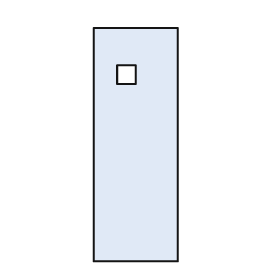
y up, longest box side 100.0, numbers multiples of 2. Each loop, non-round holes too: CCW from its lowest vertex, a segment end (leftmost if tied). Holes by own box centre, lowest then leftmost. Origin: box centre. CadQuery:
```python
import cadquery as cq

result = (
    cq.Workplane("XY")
    .moveTo(-18.0, -50.0)
    .lineTo(18.0, -50.0)
    .lineTo(18.0, 50.0)
    .lineTo(-18.0, 50.0)
    .close()
    .moveTo(-8.0, 26.0)
    .lineTo(0.0, 26.0)
    .lineTo(0.0, 34.0)
    .lineTo(-8.0, 34.0)
    .close()
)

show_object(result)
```